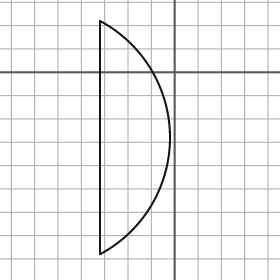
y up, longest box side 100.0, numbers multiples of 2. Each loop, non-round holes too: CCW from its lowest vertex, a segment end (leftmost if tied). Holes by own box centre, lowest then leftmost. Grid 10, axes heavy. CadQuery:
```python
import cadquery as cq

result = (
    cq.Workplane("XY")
    .moveTo(-32.0, -78.0)
    .threePointArc((-2.0, -28.0), (-32.0, 22.0))
    .close()
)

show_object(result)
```